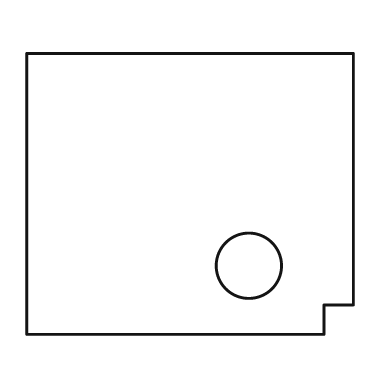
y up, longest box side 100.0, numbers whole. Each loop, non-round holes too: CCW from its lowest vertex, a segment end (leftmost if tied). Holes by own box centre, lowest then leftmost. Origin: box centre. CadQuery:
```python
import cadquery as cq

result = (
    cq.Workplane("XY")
    .moveTo(-50.0, -43.0)
    .lineTo(41.0, -43.0)
    .lineTo(41.0, -34.0)
    .lineTo(50.0, -34.0)
    .lineTo(50.0, 43.0)
    .lineTo(-50.0, 43.0)
    .close()
    .moveTo(18.0, -22.0)
    .circle(10.0)
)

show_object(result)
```